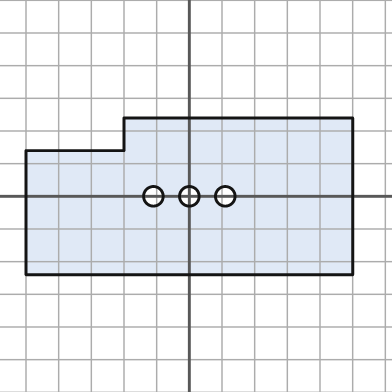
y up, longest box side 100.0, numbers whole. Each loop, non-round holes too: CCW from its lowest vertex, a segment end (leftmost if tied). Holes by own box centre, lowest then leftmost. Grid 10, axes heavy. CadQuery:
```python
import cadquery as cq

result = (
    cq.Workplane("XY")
    .moveTo(-50.0, -24.0)
    .lineTo(50.0, -24.0)
    .lineTo(50.0, 24.0)
    .lineTo(-20.0, 24.0)
    .lineTo(-20.0, 14.0)
    .lineTo(-50.0, 14.0)
    .close()
    .moveTo(-11.0, 0.0)
    .circle(3.0)
    .moveTo(0.0, 0.0)
    .circle(3.0)
    .moveTo(11.0, 0.0)
    .circle(3.0)
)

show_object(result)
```